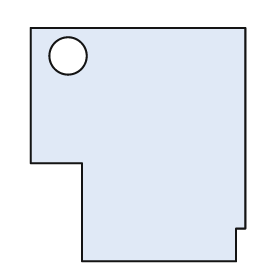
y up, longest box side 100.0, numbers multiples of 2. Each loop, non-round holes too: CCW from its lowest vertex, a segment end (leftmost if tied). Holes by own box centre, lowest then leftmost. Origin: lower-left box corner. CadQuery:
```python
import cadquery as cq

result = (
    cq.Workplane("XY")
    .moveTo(22.0, 0.0)
    .lineTo(88.0, 0.0)
    .lineTo(88.0, 14.0)
    .lineTo(92.0, 14.0)
    .lineTo(92.0, 100.0)
    .lineTo(0.0, 100.0)
    .lineTo(0.0, 42.0)
    .lineTo(22.0, 42.0)
    .close()
    .moveTo(16.0, 88.0)
    .circle(8.0)
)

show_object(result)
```